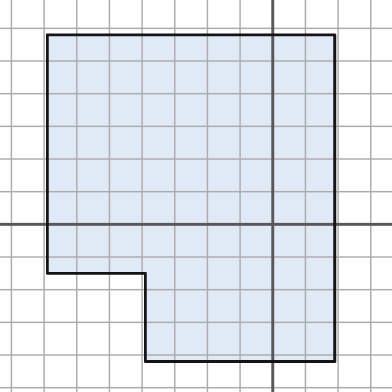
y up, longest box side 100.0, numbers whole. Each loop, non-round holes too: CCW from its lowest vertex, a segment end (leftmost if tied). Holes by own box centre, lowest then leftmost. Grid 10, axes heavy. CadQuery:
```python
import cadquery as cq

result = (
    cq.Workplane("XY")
    .moveTo(-39.0, -42.0)
    .lineTo(19.0, -42.0)
    .lineTo(19.0, 58.0)
    .lineTo(-69.0, 58.0)
    .lineTo(-69.0, -15.0)
    .lineTo(-39.0, -15.0)
    .close()
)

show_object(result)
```